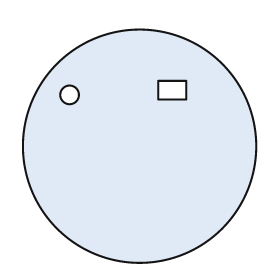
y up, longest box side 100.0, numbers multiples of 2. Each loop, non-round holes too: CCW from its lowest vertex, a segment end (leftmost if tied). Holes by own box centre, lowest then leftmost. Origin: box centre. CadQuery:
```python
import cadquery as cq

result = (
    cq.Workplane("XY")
    .moveTo(0.0, 0.0)
    .circle(50.0)
    .moveTo(-30.0, 22.0)
    .circle(4.0)
    .moveTo(8.0, 20.0)
    .lineTo(20.0, 20.0)
    .lineTo(20.0, 28.0)
    .lineTo(8.0, 28.0)
    .close()
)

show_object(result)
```